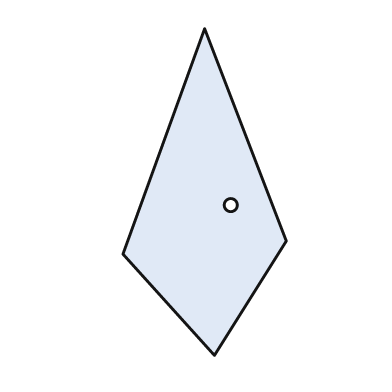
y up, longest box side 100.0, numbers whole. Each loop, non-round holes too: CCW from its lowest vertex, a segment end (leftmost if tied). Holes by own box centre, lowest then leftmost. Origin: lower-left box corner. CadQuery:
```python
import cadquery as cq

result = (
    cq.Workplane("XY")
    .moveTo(28.0, 0.0)
    .lineTo(50.0, 35.0)
    .lineTo(25.0, 100.0)
    .lineTo(0.0, 31.0)
    .close()
    .moveTo(33.0, 46.0)
    .circle(2.0)
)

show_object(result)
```